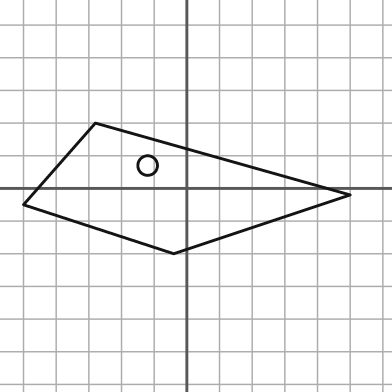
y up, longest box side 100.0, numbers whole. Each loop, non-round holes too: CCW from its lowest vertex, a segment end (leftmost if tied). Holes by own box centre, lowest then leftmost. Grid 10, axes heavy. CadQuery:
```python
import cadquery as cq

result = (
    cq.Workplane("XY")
    .moveTo(-4.0, -20.0)
    .lineTo(50.0, -2.0)
    .lineTo(-28.0, 20.0)
    .lineTo(-50.0, -5.0)
    .close()
    .moveTo(-12.0, 7.0)
    .circle(3.0)
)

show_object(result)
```